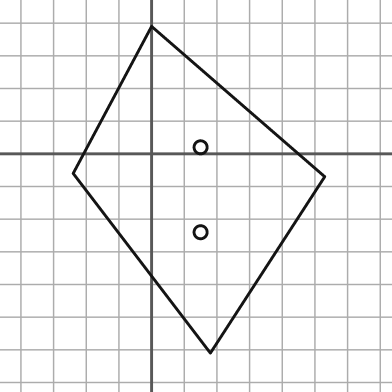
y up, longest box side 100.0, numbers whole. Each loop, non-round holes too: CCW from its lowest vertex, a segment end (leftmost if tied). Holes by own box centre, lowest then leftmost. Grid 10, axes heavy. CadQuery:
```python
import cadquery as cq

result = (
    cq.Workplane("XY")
    .moveTo(18.0, -61.0)
    .lineTo(53.0, -7.0)
    .lineTo(0.0, 39.0)
    .lineTo(-24.0, -6.0)
    .close()
    .moveTo(15.0, -24.0)
    .circle(2.0)
    .moveTo(15.0, 2.0)
    .circle(2.0)
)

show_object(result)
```